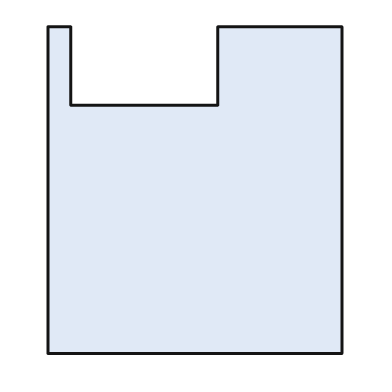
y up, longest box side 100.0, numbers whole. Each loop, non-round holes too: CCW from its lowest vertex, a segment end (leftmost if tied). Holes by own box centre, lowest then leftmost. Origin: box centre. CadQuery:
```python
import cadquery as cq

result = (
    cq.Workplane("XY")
    .moveTo(-45.0, -50.0)
    .lineTo(45.0, -50.0)
    .lineTo(45.0, 50.0)
    .lineTo(7.0, 50.0)
    .lineTo(7.0, 26.0)
    .lineTo(-38.0, 26.0)
    .lineTo(-38.0, 50.0)
    .lineTo(-45.0, 50.0)
    .close()
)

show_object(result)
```